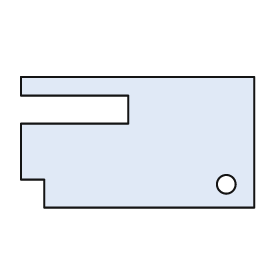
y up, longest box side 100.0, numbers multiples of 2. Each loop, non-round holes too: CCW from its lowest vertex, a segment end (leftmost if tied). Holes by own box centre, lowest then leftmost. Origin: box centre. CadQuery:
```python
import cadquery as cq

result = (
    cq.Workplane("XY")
    .moveTo(-40.0, -28.0)
    .lineTo(50.0, -28.0)
    .lineTo(50.0, 28.0)
    .lineTo(-50.0, 28.0)
    .lineTo(-50.0, 20.0)
    .lineTo(-4.0, 20.0)
    .lineTo(-4.0, 8.0)
    .lineTo(-50.0, 8.0)
    .lineTo(-50.0, -16.0)
    .lineTo(-40.0, -16.0)
    .close()
    .moveTo(38.0, -18.0)
    .circle(4.0)
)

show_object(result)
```